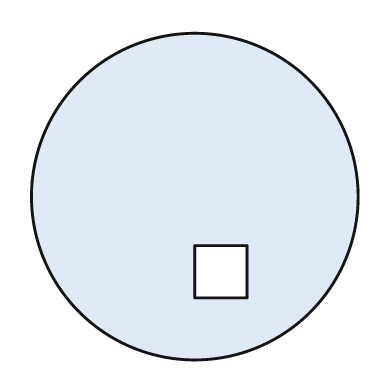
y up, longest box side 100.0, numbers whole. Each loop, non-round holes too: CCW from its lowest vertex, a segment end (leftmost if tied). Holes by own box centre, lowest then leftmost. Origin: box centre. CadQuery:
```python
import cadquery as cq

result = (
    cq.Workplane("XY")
    .moveTo(0.0, 0.0)
    .circle(50.0)
    .moveTo(0.0, -31.0)
    .lineTo(16.0, -31.0)
    .lineTo(16.0, -15.0)
    .lineTo(0.0, -15.0)
    .close()
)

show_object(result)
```